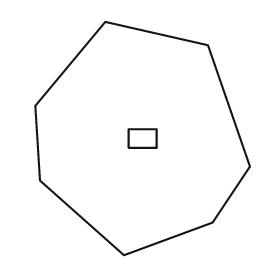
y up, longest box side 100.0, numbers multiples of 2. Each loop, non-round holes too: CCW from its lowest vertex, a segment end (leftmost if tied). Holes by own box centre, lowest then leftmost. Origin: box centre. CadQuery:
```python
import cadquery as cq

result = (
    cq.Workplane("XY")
    .moveTo(-8.0, -50.0)
    .lineTo(30.0, -36.0)
    .lineTo(46.0, -12.0)
    .lineTo(28.0, 40.0)
    .lineTo(-16.0, 50.0)
    .lineTo(-46.0, 14.0)
    .lineTo(-44.0, -18.0)
    .close()
    .moveTo(-6.0, -4.0)
    .lineTo(6.0, -4.0)
    .lineTo(6.0, 4.0)
    .lineTo(-6.0, 4.0)
    .close()
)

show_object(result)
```